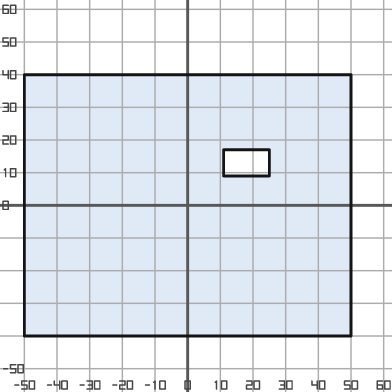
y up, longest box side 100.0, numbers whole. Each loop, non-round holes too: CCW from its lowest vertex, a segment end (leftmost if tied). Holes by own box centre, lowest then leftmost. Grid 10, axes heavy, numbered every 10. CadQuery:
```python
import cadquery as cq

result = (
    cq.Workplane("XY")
    .moveTo(-50.0, -40.0)
    .lineTo(50.0, -40.0)
    .lineTo(50.0, 40.0)
    .lineTo(-50.0, 40.0)
    .close()
    .moveTo(11.0, 9.0)
    .lineTo(25.0, 9.0)
    .lineTo(25.0, 17.0)
    .lineTo(11.0, 17.0)
    .close()
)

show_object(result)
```